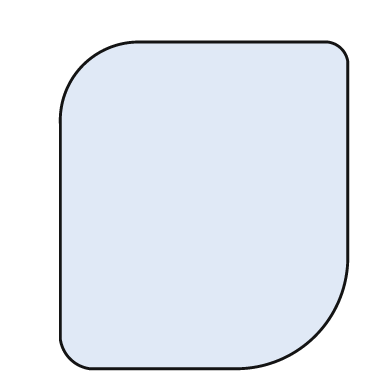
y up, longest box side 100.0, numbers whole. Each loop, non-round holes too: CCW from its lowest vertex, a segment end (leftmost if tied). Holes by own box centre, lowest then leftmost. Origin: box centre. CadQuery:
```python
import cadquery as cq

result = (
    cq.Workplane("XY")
    .moveTo(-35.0, -50.0)
    .lineTo(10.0, -50.0)
    .threePointArc((34.0, -40.0), (44.0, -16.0))
    .lineTo(44.0, 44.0)
    .threePointArc((42.0, 48.0), (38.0, 50.0))
    .lineTo(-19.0, 50.0)
    .threePointArc((-37.0, 43.0), (-44.0, 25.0))
    .lineTo(-44.0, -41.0)
    .threePointArc((-41.0, -47.0), (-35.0, -50.0))
    .close()
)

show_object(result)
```